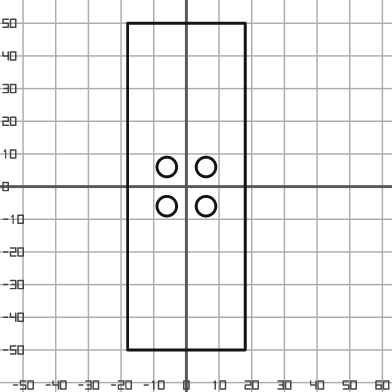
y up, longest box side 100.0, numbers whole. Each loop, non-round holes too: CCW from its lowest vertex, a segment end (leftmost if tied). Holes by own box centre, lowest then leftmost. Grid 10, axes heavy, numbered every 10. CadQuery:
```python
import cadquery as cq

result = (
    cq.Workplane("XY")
    .moveTo(-18.0, -50.0)
    .lineTo(18.0, -50.0)
    .lineTo(18.0, 50.0)
    .lineTo(-18.0, 50.0)
    .close()
    .moveTo(-6.0, -6.0)
    .circle(3.0)
    .moveTo(6.0, -6.0)
    .circle(3.0)
    .moveTo(-6.0, 6.0)
    .circle(3.0)
    .moveTo(6.0, 6.0)
    .circle(3.0)
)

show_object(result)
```